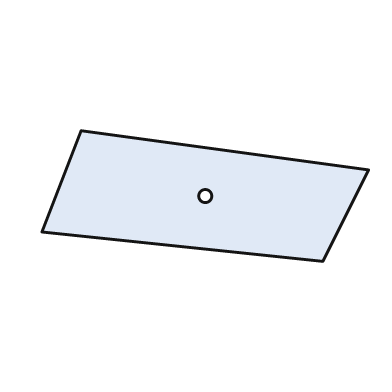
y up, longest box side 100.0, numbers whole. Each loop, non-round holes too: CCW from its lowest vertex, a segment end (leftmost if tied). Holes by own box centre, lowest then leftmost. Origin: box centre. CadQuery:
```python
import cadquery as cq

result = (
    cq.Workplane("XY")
    .moveTo(36.0, -20.0)
    .lineTo(50.0, 8.0)
    .lineTo(-38.0, 20.0)
    .lineTo(-50.0, -11.0)
    .close()
    .moveTo(0.0, 0.0)
    .circle(2.0)
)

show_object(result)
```